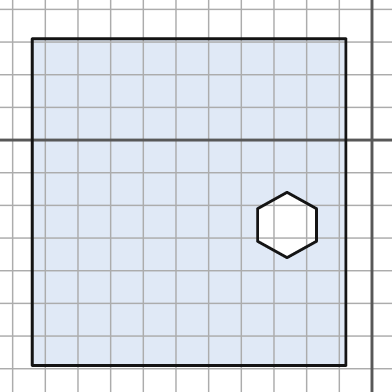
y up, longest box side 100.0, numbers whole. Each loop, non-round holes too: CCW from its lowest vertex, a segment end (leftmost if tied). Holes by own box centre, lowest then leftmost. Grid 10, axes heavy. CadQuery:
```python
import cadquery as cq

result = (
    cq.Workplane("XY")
    .moveTo(-104.0, -69.0)
    .lineTo(-8.0, -69.0)
    .lineTo(-8.0, 31.0)
    .lineTo(-104.0, 31.0)
    .close()
    .moveTo(-26.0, -36.0)
    .lineTo(-17.0, -31.0)
    .lineTo(-17.0, -21.0)
    .lineTo(-26.0, -16.0)
    .lineTo(-35.0, -21.0)
    .lineTo(-35.0, -31.0)
    .close()
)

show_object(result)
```